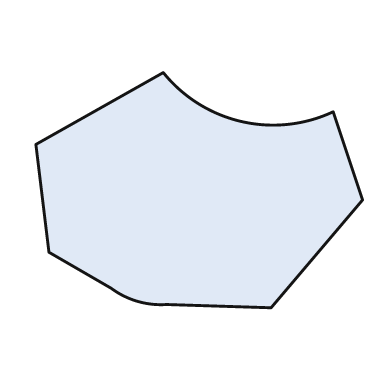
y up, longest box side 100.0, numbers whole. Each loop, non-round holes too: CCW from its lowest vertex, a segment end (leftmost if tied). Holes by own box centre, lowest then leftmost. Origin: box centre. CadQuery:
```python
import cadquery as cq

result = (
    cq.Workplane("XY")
    .moveTo(22.0, -36.0)
    .lineTo(50.0, -3.0)
    .lineTo(41.0, 24.0)
    .threePointArc((13.0, 21.0), (-11.0, 36.0))
    .lineTo(-50.0, 14.0)
    .lineTo(-46.0, -19.0)
    .lineTo(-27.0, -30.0)
    .threePointArc((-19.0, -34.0), (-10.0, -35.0))
    .close()
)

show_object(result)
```